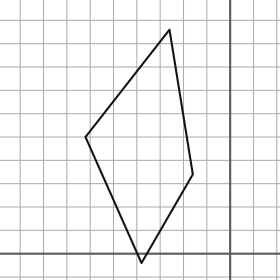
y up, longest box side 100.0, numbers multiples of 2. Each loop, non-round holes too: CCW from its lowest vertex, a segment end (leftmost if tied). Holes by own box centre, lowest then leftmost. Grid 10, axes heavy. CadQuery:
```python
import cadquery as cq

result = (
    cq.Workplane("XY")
    .moveTo(-38.0, -4.0)
    .lineTo(-16.0, 34.0)
    .lineTo(-26.0, 96.0)
    .lineTo(-62.0, 50.0)
    .close()
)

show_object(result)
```